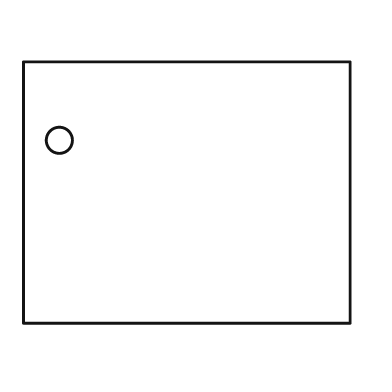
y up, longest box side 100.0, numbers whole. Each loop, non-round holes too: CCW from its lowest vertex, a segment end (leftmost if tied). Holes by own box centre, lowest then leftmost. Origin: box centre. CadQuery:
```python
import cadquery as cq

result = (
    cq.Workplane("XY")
    .moveTo(-50.0, -40.0)
    .lineTo(50.0, -40.0)
    .lineTo(50.0, 40.0)
    .lineTo(-50.0, 40.0)
    .close()
    .moveTo(-39.0, 16.0)
    .circle(4.0)
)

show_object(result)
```